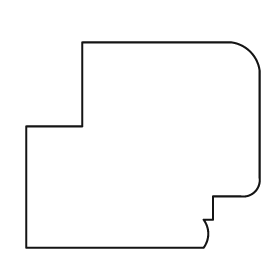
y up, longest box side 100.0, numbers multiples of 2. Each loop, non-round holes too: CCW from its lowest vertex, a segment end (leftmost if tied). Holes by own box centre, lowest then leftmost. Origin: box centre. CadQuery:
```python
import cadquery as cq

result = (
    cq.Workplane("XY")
    .moveTo(-50.0, -44.0)
    .lineTo(26.0, -44.0)
    .threePointArc((28.0, -38.0), (26.0, -32.0))
    .lineTo(30.0, -32.0)
    .lineTo(30.0, -22.0)
    .lineTo(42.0, -22.0)
    .threePointArc((48.0, -20.0), (50.0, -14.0))
    .lineTo(50.0, 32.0)
    .threePointArc((46.0, 40.0), (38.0, 44.0))
    .lineTo(-26.0, 44.0)
    .lineTo(-26.0, 8.0)
    .lineTo(-50.0, 8.0)
    .close()
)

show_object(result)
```